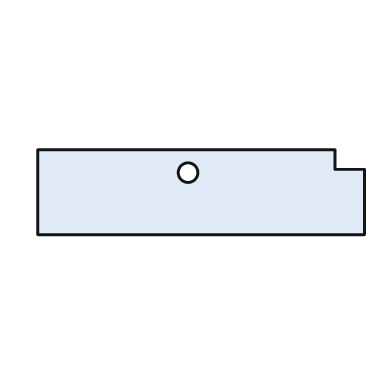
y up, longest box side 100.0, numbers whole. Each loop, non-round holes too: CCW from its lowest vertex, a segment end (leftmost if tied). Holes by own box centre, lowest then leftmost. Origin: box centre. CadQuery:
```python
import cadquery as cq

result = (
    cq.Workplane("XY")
    .moveTo(-50.0, -13.0)
    .lineTo(50.0, -13.0)
    .lineTo(50.0, 7.0)
    .lineTo(41.0, 7.0)
    .lineTo(41.0, 13.0)
    .lineTo(-50.0, 13.0)
    .close()
    .moveTo(-4.0, 6.0)
    .circle(3.0)
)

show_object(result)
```